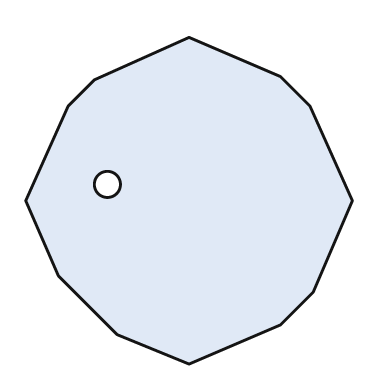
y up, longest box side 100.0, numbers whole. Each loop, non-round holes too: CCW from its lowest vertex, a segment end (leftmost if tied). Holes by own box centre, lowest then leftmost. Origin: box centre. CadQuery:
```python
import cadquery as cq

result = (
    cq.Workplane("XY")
    .moveTo(0.0, -50.0)
    .lineTo(28.0, -38.0)
    .lineTo(38.0, -28.0)
    .lineTo(50.0, 0.0)
    .lineTo(37.0, 29.0)
    .lineTo(28.0, 38.0)
    .lineTo(0.0, 50.0)
    .lineTo(-29.0, 37.0)
    .lineTo(-37.0, 29.0)
    .lineTo(-50.0, 0.0)
    .lineTo(-40.0, -23.0)
    .lineTo(-22.0, -41.0)
    .close()
    .moveTo(-25.0, 5.0)
    .circle(4.0)
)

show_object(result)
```